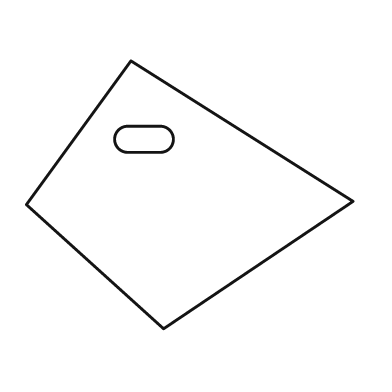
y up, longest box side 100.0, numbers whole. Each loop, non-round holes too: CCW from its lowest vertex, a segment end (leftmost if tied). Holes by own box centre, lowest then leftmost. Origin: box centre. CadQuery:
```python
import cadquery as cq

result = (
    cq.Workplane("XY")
    .moveTo(-8.0, -41.0)
    .lineTo(50.0, -2.0)
    .lineTo(-18.0, 41.0)
    .lineTo(-50.0, -3.0)
    .close()
    .moveTo(-19.0, 13.0)
    .lineTo(-9.0, 13.0)
    .threePointArc((-5.0, 17.0), (-9.0, 21.0))
    .lineTo(-19.0, 21.0)
    .threePointArc((-23.0, 17.0), (-19.0, 13.0))
    .close()
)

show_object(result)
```